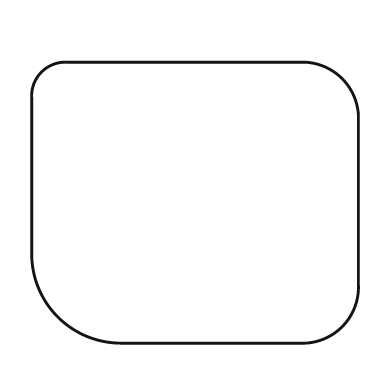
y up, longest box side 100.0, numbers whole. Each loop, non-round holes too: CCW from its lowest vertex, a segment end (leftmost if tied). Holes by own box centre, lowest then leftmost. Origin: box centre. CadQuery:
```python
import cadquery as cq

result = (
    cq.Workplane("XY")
    .moveTo(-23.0, -43.0)
    .lineTo(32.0, -43.0)
    .threePointArc((45.0, -38.0), (50.0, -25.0))
    .lineTo(50.0, 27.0)
    .threePointArc((45.0, 38.0), (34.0, 43.0))
    .lineTo(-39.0, 43.0)
    .threePointArc((-47.0, 40.0), (-50.0, 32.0))
    .lineTo(-50.0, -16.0)
    .threePointArc((-42.0, -35.0), (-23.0, -43.0))
    .close()
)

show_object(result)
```